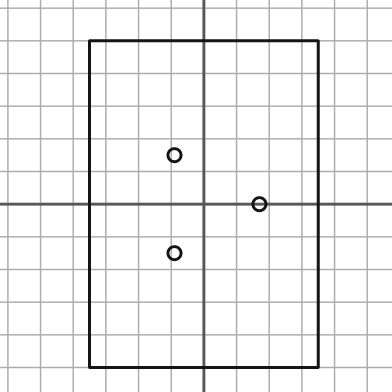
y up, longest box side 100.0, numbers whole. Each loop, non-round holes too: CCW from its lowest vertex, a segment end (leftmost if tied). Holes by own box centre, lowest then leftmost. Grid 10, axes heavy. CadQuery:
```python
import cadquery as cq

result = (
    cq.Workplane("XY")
    .moveTo(-35.0, -50.0)
    .lineTo(35.0, -50.0)
    .lineTo(35.0, 50.0)
    .lineTo(-35.0, 50.0)
    .close()
    .moveTo(-9.0, -15.0)
    .circle(2.0)
    .moveTo(17.0, 0.0)
    .circle(2.0)
    .moveTo(-9.0, 15.0)
    .circle(2.0)
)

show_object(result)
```